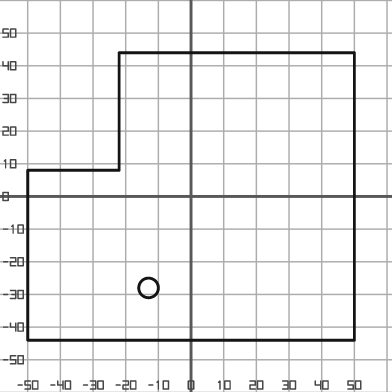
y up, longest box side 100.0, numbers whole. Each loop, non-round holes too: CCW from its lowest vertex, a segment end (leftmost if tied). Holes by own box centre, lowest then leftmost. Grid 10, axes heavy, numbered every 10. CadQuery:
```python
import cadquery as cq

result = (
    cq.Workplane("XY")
    .moveTo(-50.0, -44.0)
    .lineTo(50.0, -44.0)
    .lineTo(50.0, 44.0)
    .lineTo(-22.0, 44.0)
    .lineTo(-22.0, 8.0)
    .lineTo(-50.0, 8.0)
    .close()
    .moveTo(-13.0, -28.0)
    .circle(3.0)
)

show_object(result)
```